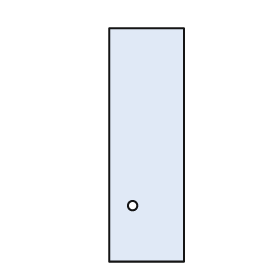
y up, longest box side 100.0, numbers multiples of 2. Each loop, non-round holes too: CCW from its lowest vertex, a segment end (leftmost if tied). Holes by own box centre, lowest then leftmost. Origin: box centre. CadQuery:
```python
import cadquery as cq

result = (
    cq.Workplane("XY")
    .moveTo(-16.0, -50.0)
    .lineTo(16.0, -50.0)
    .lineTo(16.0, 50.0)
    .lineTo(-16.0, 50.0)
    .close()
    .moveTo(-6.0, -26.0)
    .circle(2.0)
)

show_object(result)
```